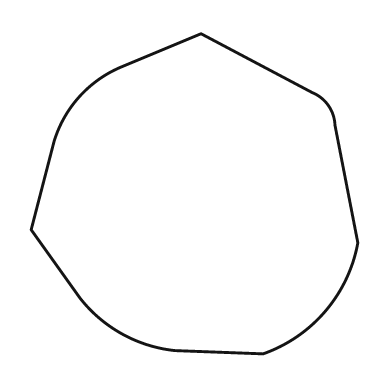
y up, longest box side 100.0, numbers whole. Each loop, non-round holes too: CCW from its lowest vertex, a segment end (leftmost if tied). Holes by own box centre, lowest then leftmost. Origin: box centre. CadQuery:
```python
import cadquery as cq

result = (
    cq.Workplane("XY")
    .moveTo(21.0, -49.0)
    .threePointArc((40.0, -36.0), (50.0, -15.0))
    .lineTo(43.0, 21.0)
    .threePointArc((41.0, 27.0), (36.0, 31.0))
    .lineTo(2.0, 49.0)
    .lineTo(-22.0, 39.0)
    .threePointArc((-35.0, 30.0), (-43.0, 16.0))
    .lineTo(-50.0, -11.0)
    .lineTo(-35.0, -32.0)
    .threePointArc((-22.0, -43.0), (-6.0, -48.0))
    .close()
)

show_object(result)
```